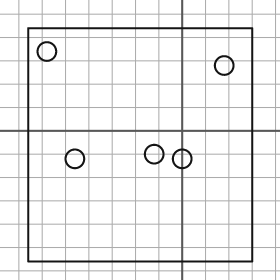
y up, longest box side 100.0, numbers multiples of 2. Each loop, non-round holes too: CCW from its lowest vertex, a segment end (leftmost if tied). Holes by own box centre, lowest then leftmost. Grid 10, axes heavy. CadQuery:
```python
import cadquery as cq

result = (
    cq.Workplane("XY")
    .moveTo(-66.0, -56.0)
    .lineTo(30.0, -56.0)
    .lineTo(30.0, 44.0)
    .lineTo(-66.0, 44.0)
    .close()
    .moveTo(-46.0, -12.0)
    .circle(4.0)
    .moveTo(0.0, -12.0)
    .circle(4.0)
    .moveTo(-12.0, -10.0)
    .circle(4.0)
    .moveTo(18.0, 28.0)
    .circle(4.0)
    .moveTo(-58.0, 34.0)
    .circle(4.0)
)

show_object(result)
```